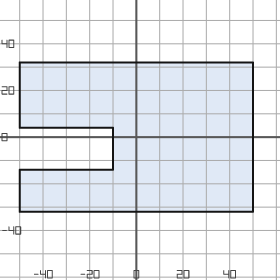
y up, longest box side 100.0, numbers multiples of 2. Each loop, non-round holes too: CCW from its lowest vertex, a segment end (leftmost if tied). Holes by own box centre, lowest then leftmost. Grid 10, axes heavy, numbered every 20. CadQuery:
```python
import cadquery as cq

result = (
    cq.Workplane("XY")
    .moveTo(-50.0, -32.0)
    .lineTo(50.0, -32.0)
    .lineTo(50.0, 32.0)
    .lineTo(-50.0, 32.0)
    .lineTo(-50.0, 4.0)
    .lineTo(-10.0, 4.0)
    .lineTo(-10.0, -14.0)
    .lineTo(-50.0, -14.0)
    .close()
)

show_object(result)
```